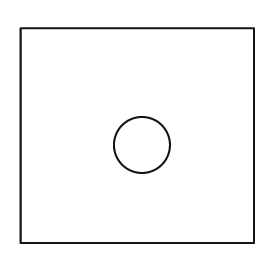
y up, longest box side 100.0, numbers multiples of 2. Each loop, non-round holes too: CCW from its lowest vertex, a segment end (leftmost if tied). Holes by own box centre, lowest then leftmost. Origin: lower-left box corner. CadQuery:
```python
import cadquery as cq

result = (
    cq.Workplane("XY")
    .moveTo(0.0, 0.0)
    .lineTo(100.0, 0.0)
    .lineTo(100.0, 92.0)
    .lineTo(0.0, 92.0)
    .close()
    .moveTo(52.0, 42.0)
    .circle(12.0)
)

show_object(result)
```